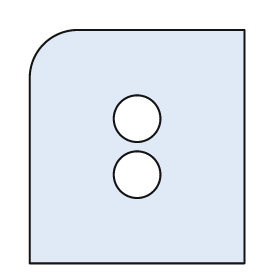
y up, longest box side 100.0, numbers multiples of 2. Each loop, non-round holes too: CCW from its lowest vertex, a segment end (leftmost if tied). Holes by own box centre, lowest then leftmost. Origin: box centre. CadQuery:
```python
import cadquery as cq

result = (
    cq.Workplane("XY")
    .moveTo(-46.0, -50.0)
    .lineTo(46.0, -50.0)
    .lineTo(46.0, 50.0)
    .lineTo(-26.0, 50.0)
    .threePointArc((-40.0, 44.0), (-46.0, 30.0))
    .close()
    .moveTo(0.0, -12.0)
    .circle(10.0)
    .moveTo(0.0, 12.0)
    .circle(10.0)
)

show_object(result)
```